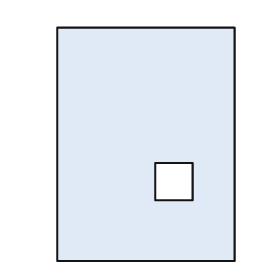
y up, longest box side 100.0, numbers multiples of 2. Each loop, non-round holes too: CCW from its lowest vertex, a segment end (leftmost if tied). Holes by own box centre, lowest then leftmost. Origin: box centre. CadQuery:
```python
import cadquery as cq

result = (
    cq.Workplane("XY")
    .moveTo(-38.0, -50.0)
    .lineTo(38.0, -50.0)
    .lineTo(38.0, 50.0)
    .lineTo(-38.0, 50.0)
    .close()
    .moveTo(4.0, -24.0)
    .lineTo(20.0, -24.0)
    .lineTo(20.0, -8.0)
    .lineTo(4.0, -8.0)
    .close()
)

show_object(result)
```